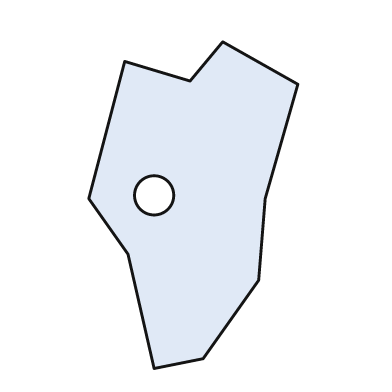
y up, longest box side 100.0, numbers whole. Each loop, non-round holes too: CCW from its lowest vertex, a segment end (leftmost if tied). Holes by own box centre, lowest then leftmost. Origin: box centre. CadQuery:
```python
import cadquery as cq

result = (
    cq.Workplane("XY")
    .moveTo(-12.0, -50.0)
    .lineTo(3.0, -47.0)
    .lineTo(20.0, -23.0)
    .lineTo(22.0, 2.0)
    .lineTo(32.0, 37.0)
    .lineTo(9.0, 50.0)
    .lineTo(-1.0, 38.0)
    .lineTo(-21.0, 44.0)
    .lineTo(-32.0, 2.0)
    .lineTo(-20.0, -15.0)
    .close()
    .moveTo(-12.0, 3.0)
    .circle(6.0)
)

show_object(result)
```